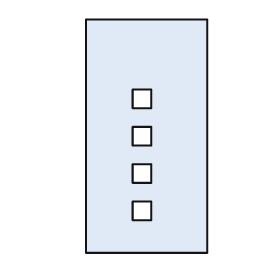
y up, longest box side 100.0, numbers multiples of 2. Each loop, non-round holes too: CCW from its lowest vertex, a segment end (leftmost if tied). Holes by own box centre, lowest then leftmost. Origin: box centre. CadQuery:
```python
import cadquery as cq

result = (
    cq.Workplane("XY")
    .moveTo(-26.0, -50.0)
    .lineTo(26.0, -50.0)
    .lineTo(26.0, 50.0)
    .lineTo(-26.0, 50.0)
    .close()
    .moveTo(-6.0, -36.0)
    .lineTo(2.0, -36.0)
    .lineTo(2.0, -28.0)
    .lineTo(-6.0, -28.0)
    .close()
    .moveTo(-6.0, -20.0)
    .lineTo(2.0, -20.0)
    .lineTo(2.0, -12.0)
    .lineTo(-6.0, -12.0)
    .close()
    .moveTo(-6.0, -4.0)
    .lineTo(2.0, -4.0)
    .lineTo(2.0, 4.0)
    .lineTo(-6.0, 4.0)
    .close()
    .moveTo(-6.0, 12.0)
    .lineTo(2.0, 12.0)
    .lineTo(2.0, 20.0)
    .lineTo(-6.0, 20.0)
    .close()
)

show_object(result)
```